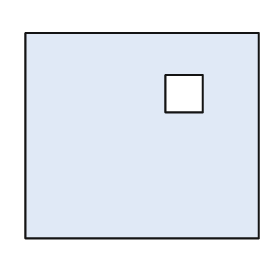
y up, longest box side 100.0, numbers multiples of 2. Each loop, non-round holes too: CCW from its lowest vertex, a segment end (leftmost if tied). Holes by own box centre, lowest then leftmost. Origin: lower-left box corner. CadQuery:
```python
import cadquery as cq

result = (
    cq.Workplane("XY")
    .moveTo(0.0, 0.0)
    .lineTo(100.0, 0.0)
    .lineTo(100.0, 88.0)
    .lineTo(0.0, 88.0)
    .close()
    .moveTo(60.0, 54.0)
    .lineTo(76.0, 54.0)
    .lineTo(76.0, 70.0)
    .lineTo(60.0, 70.0)
    .close()
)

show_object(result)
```